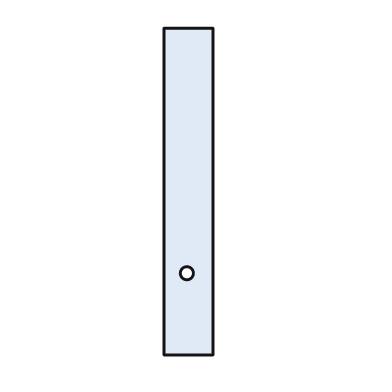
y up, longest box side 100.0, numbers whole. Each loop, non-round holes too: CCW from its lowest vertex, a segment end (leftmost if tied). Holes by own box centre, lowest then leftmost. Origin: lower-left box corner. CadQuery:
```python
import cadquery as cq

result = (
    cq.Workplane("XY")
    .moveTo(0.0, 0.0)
    .lineTo(15.0, 0.0)
    .lineTo(15.0, 100.0)
    .lineTo(0.0, 100.0)
    .close()
    .moveTo(7.0, 25.0)
    .circle(2.0)
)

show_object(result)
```